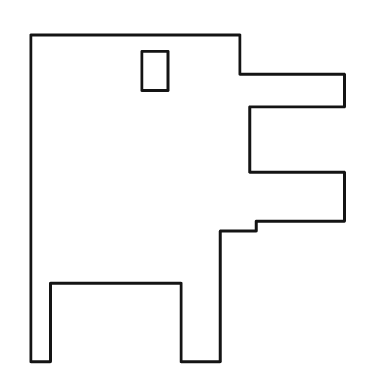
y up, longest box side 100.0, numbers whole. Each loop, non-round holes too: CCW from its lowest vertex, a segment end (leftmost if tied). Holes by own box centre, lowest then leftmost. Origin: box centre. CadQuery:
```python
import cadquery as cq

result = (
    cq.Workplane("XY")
    .moveTo(-48.0, -50.0)
    .lineTo(-42.0, -50.0)
    .lineTo(-42.0, -26.0)
    .lineTo(-2.0, -26.0)
    .lineTo(-2.0, -50.0)
    .lineTo(10.0, -50.0)
    .lineTo(10.0, -10.0)
    .lineTo(21.0, -10.0)
    .lineTo(21.0, -7.0)
    .lineTo(48.0, -7.0)
    .lineTo(48.0, 8.0)
    .lineTo(19.0, 8.0)
    .lineTo(19.0, 28.0)
    .lineTo(48.0, 28.0)
    .lineTo(48.0, 38.0)
    .lineTo(16.0, 38.0)
    .lineTo(16.0, 50.0)
    .lineTo(-48.0, 50.0)
    .close()
    .moveTo(-14.0, 33.0)
    .lineTo(-6.0, 33.0)
    .lineTo(-6.0, 45.0)
    .lineTo(-14.0, 45.0)
    .close()
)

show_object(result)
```